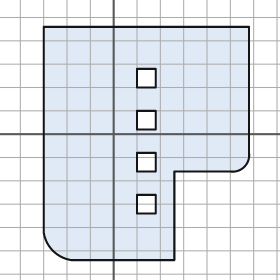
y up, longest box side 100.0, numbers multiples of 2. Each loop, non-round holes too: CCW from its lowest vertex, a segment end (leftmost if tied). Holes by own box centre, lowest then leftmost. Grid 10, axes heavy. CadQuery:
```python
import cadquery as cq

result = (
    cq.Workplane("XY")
    .moveTo(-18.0, -54.0)
    .lineTo(26.0, -54.0)
    .lineTo(26.0, -16.0)
    .lineTo(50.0, -16.0)
    .threePointArc((56.0, -14.0), (58.0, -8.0))
    .lineTo(58.0, 46.0)
    .lineTo(-30.0, 46.0)
    .lineTo(-30.0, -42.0)
    .threePointArc((-26.0, -50.0), (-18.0, -54.0))
    .close()
    .moveTo(10.0, -34.0)
    .lineTo(18.0, -34.0)
    .lineTo(18.0, -26.0)
    .lineTo(10.0, -26.0)
    .close()
    .moveTo(10.0, -16.0)
    .lineTo(18.0, -16.0)
    .lineTo(18.0, -8.0)
    .lineTo(10.0, -8.0)
    .close()
    .moveTo(10.0, 2.0)
    .lineTo(18.0, 2.0)
    .lineTo(18.0, 10.0)
    .lineTo(10.0, 10.0)
    .close()
    .moveTo(10.0, 20.0)
    .lineTo(18.0, 20.0)
    .lineTo(18.0, 28.0)
    .lineTo(10.0, 28.0)
    .close()
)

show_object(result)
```